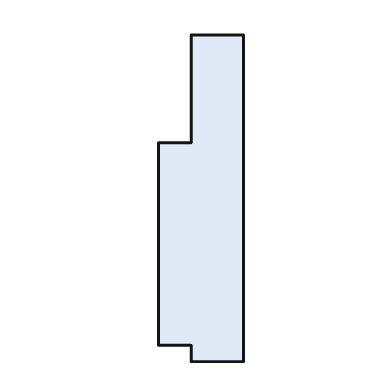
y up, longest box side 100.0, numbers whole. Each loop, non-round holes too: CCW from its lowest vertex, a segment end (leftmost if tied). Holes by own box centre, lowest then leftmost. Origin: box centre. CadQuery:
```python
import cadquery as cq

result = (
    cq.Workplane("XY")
    .moveTo(-3.0, -50.0)
    .lineTo(13.0, -50.0)
    .lineTo(13.0, 50.0)
    .lineTo(-3.0, 50.0)
    .lineTo(-3.0, 17.0)
    .lineTo(-13.0, 17.0)
    .lineTo(-13.0, -45.0)
    .lineTo(-3.0, -45.0)
    .close()
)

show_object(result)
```